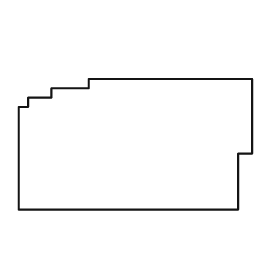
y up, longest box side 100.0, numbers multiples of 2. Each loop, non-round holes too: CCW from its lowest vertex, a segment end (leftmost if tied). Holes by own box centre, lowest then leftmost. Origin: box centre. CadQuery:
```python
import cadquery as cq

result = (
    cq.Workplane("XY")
    .moveTo(-50.0, -28.0)
    .lineTo(44.0, -28.0)
    .lineTo(44.0, -4.0)
    .lineTo(50.0, -4.0)
    .lineTo(50.0, 28.0)
    .lineTo(-20.0, 28.0)
    .lineTo(-20.0, 24.0)
    .lineTo(-36.0, 24.0)
    .lineTo(-36.0, 20.0)
    .lineTo(-46.0, 20.0)
    .lineTo(-46.0, 16.0)
    .lineTo(-50.0, 16.0)
    .close()
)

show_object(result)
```